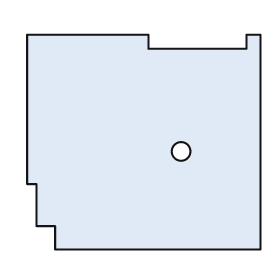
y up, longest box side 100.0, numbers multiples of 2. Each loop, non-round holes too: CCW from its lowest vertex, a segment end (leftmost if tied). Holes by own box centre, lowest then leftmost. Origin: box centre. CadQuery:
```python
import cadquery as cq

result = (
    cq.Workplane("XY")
    .moveTo(-38.0, -46.0)
    .lineTo(50.0, -46.0)
    .lineTo(50.0, 46.0)
    .lineTo(44.0, 46.0)
    .lineTo(44.0, 40.0)
    .lineTo(2.0, 40.0)
    .lineTo(2.0, 46.0)
    .lineTo(-50.0, 46.0)
    .lineTo(-50.0, -18.0)
    .lineTo(-46.0, -18.0)
    .lineTo(-46.0, -36.0)
    .lineTo(-38.0, -36.0)
    .close()
    .moveTo(16.0, -4.0)
    .circle(4.0)
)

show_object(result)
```